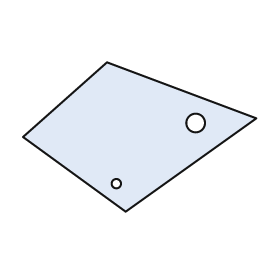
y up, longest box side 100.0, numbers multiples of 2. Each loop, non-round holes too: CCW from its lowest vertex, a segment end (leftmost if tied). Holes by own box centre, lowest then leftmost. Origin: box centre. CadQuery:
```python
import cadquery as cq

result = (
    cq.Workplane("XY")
    .moveTo(-6.0, -32.0)
    .lineTo(50.0, 8.0)
    .lineTo(-14.0, 32.0)
    .lineTo(-50.0, 0.0)
    .close()
    .moveTo(-10.0, -20.0)
    .circle(2.0)
    .moveTo(24.0, 6.0)
    .circle(4.0)
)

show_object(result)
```